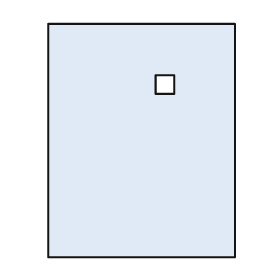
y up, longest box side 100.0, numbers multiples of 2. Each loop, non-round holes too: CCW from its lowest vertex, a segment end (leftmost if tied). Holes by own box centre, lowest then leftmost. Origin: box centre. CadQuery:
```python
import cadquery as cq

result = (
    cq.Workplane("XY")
    .moveTo(-40.0, -50.0)
    .lineTo(40.0, -50.0)
    .lineTo(40.0, 50.0)
    .lineTo(-40.0, 50.0)
    .close()
    .moveTo(6.0, 20.0)
    .lineTo(14.0, 20.0)
    .lineTo(14.0, 28.0)
    .lineTo(6.0, 28.0)
    .close()
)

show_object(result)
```